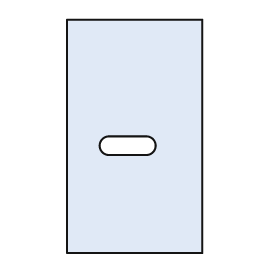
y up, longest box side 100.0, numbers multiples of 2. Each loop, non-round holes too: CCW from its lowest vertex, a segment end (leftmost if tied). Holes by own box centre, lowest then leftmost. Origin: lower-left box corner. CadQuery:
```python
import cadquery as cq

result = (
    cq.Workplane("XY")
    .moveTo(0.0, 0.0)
    .lineTo(58.0, 0.0)
    .lineTo(58.0, 100.0)
    .lineTo(0.0, 100.0)
    .close()
    .moveTo(18.0, 42.0)
    .lineTo(34.0, 42.0)
    .threePointArc((38.0, 46.0), (34.0, 50.0))
    .lineTo(18.0, 50.0)
    .threePointArc((14.0, 46.0), (18.0, 42.0))
    .close()
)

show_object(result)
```